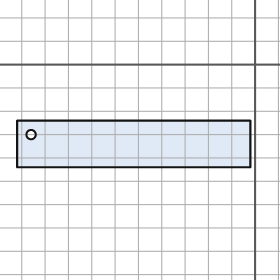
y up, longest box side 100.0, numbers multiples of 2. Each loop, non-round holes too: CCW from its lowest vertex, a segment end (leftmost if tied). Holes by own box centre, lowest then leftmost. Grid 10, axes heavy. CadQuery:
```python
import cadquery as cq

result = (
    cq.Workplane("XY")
    .moveTo(-102.0, -44.0)
    .lineTo(-2.0, -44.0)
    .lineTo(-2.0, -24.0)
    .lineTo(-102.0, -24.0)
    .close()
    .moveTo(-96.0, -30.0)
    .circle(2.0)
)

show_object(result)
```